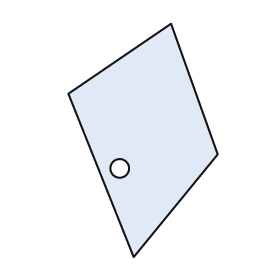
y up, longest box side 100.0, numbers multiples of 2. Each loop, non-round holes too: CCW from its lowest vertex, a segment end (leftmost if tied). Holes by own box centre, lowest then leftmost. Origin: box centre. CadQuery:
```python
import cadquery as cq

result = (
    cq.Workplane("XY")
    .moveTo(-4.0, -50.0)
    .lineTo(32.0, -6.0)
    .lineTo(12.0, 50.0)
    .lineTo(-32.0, 20.0)
    .close()
    .moveTo(-10.0, -12.0)
    .circle(4.0)
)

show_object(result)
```